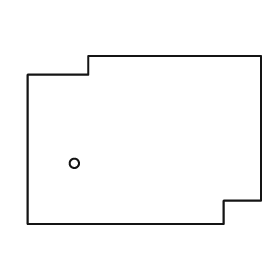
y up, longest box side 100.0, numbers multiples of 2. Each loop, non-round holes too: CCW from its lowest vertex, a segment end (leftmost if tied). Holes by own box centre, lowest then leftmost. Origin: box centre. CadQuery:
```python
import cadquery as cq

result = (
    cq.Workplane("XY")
    .moveTo(-50.0, -36.0)
    .lineTo(34.0, -36.0)
    .lineTo(34.0, -26.0)
    .lineTo(50.0, -26.0)
    .lineTo(50.0, 36.0)
    .lineTo(-24.0, 36.0)
    .lineTo(-24.0, 28.0)
    .lineTo(-50.0, 28.0)
    .close()
    .moveTo(-30.0, -10.0)
    .circle(2.0)
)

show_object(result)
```